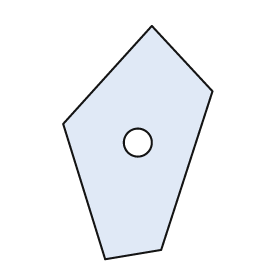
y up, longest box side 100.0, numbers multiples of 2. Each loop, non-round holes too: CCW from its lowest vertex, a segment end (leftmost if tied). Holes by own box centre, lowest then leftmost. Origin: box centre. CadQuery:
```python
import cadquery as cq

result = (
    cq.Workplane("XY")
    .moveTo(-14.0, -50.0)
    .lineTo(10.0, -46.0)
    .lineTo(32.0, 22.0)
    .lineTo(6.0, 50.0)
    .lineTo(-32.0, 8.0)
    .close()
    .moveTo(0.0, 0.0)
    .circle(6.0)
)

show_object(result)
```